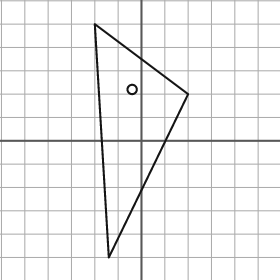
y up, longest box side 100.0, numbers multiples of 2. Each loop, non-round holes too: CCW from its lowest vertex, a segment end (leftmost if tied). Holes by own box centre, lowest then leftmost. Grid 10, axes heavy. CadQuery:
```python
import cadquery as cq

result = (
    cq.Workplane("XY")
    .moveTo(-14.0, -50.0)
    .lineTo(20.0, 20.0)
    .lineTo(-20.0, 50.0)
    .close()
    .moveTo(-4.0, 22.0)
    .circle(2.0)
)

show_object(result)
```